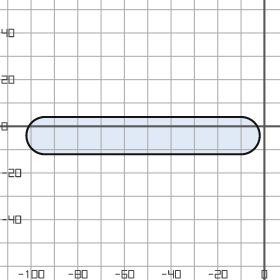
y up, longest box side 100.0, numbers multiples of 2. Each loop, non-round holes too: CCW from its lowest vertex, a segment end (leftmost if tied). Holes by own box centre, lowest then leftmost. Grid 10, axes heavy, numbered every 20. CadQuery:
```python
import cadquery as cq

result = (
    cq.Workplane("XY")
    .moveTo(-94.0, -12.0)
    .lineTo(-10.0, -12.0)
    .threePointArc((-2.0, -4.0), (-10.0, 4.0))
    .lineTo(-94.0, 4.0)
    .threePointArc((-102.0, -4.0), (-94.0, -12.0))
    .close()
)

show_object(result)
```